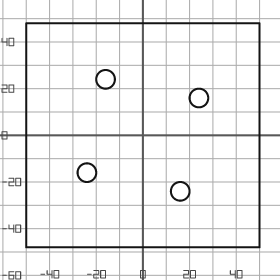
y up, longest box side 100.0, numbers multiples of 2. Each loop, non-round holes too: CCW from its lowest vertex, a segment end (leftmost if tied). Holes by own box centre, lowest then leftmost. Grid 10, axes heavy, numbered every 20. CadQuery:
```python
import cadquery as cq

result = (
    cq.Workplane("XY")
    .moveTo(-50.0, -48.0)
    .lineTo(50.0, -48.0)
    .lineTo(50.0, 48.0)
    .lineTo(-50.0, 48.0)
    .close()
    .moveTo(16.0, -24.0)
    .circle(4.0)
    .moveTo(-24.0, -16.0)
    .circle(4.0)
    .moveTo(24.0, 16.0)
    .circle(4.0)
    .moveTo(-16.0, 24.0)
    .circle(4.0)
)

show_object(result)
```